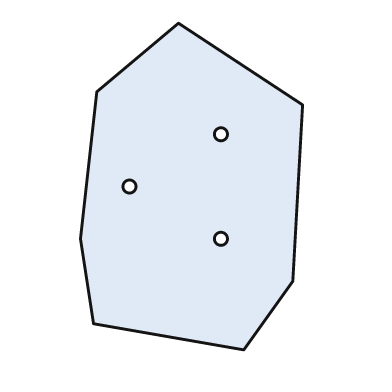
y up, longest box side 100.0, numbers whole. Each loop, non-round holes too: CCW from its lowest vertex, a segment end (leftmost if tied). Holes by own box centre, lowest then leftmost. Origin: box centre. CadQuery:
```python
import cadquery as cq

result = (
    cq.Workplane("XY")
    .moveTo(16.0, -50.0)
    .lineTo(31.0, -29.0)
    .lineTo(34.0, 25.0)
    .lineTo(-4.0, 50.0)
    .lineTo(-29.0, 29.0)
    .lineTo(-34.0, -16.0)
    .lineTo(-30.0, -42.0)
    .close()
    .moveTo(9.0, -16.0)
    .circle(2.0)
    .moveTo(-19.0, 0.0)
    .circle(2.0)
    .moveTo(9.0, 16.0)
    .circle(2.0)
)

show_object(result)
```